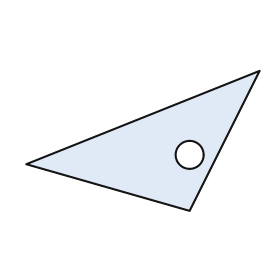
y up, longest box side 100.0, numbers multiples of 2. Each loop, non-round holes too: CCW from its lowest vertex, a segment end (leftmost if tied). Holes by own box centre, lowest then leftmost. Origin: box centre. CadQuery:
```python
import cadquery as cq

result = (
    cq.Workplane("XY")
    .moveTo(20.0, -30.0)
    .lineTo(50.0, 30.0)
    .lineTo(-50.0, -10.0)
    .close()
    .moveTo(20.0, -6.0)
    .circle(6.0)
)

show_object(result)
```